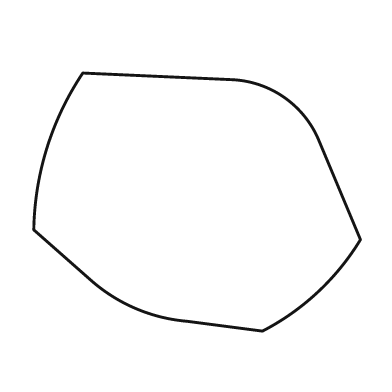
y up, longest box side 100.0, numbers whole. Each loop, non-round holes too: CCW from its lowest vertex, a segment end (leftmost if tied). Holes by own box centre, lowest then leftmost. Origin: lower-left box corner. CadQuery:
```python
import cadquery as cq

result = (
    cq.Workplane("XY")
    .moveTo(70.0, 0.0)
    .threePointArc((87.0, 12.0), (100.0, 28.0))
    .lineTo(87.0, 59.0)
    .threePointArc((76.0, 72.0), (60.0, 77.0))
    .lineTo(15.0, 79.0)
    .threePointArc((4.0, 56.0), (0.0, 31.0))
    .lineTo(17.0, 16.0)
    .threePointArc((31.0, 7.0), (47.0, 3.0))
    .close()
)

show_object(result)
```